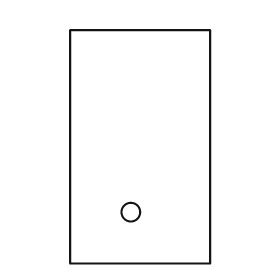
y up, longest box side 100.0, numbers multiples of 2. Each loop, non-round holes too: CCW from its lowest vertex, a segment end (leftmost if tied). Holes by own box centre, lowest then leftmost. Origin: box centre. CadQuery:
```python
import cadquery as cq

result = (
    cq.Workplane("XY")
    .moveTo(-30.0, -50.0)
    .lineTo(30.0, -50.0)
    .lineTo(30.0, 50.0)
    .lineTo(-30.0, 50.0)
    .close()
    .moveTo(-4.0, -28.0)
    .circle(4.0)
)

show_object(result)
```